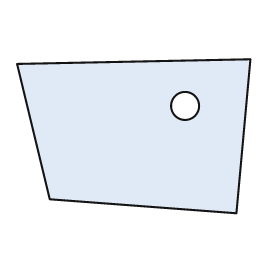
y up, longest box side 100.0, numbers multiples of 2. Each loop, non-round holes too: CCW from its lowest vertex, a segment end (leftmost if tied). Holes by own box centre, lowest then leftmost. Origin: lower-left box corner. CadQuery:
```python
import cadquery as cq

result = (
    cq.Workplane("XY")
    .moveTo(94.0, 0.0)
    .lineTo(100.0, 66.0)
    .lineTo(0.0, 64.0)
    .lineTo(14.0, 6.0)
    .close()
    .moveTo(72.0, 46.0)
    .circle(6.0)
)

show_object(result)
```